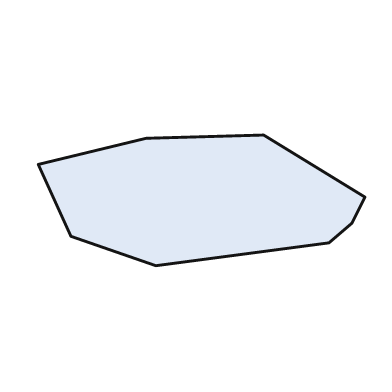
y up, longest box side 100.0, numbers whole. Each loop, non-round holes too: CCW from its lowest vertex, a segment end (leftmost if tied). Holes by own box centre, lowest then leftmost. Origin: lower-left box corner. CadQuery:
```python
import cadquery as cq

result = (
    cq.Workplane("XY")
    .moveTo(36.0, 0.0)
    .lineTo(89.0, 7.0)
    .lineTo(96.0, 13.0)
    .lineTo(100.0, 21.0)
    .lineTo(69.0, 40.0)
    .lineTo(33.0, 39.0)
    .lineTo(0.0, 31.0)
    .lineTo(10.0, 9.0)
    .close()
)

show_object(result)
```